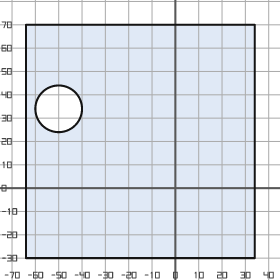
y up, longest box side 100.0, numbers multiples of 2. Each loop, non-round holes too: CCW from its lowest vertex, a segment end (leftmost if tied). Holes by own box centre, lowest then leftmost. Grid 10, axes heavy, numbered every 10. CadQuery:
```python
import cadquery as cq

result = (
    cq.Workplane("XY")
    .moveTo(-64.0, -30.0)
    .lineTo(34.0, -30.0)
    .lineTo(34.0, 70.0)
    .lineTo(-64.0, 70.0)
    .close()
    .moveTo(-50.0, 34.0)
    .circle(10.0)
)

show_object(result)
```